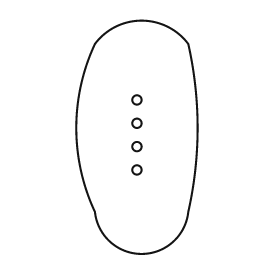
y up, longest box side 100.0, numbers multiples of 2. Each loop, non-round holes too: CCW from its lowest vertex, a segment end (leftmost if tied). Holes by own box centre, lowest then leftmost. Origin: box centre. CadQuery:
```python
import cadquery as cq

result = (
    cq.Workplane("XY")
    .moveTo(-18.0, -32.0)
    .threePointArc((2.0, -50.0), (22.0, -32.0))
    .threePointArc((26.0, 4.0), (22.0, 40.0))
    .threePointArc((2.0, 50.0), (-18.0, 40.0))
    .threePointArc((-26.0, 4.0), (-18.0, -32.0))
    .close()
    .moveTo(0.0, -14.0)
    .circle(2.0)
    .moveTo(0.0, -4.0)
    .circle(2.0)
    .moveTo(0.0, 6.0)
    .circle(2.0)
    .moveTo(0.0, 16.0)
    .circle(2.0)
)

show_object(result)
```